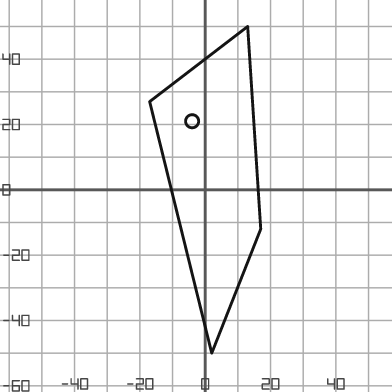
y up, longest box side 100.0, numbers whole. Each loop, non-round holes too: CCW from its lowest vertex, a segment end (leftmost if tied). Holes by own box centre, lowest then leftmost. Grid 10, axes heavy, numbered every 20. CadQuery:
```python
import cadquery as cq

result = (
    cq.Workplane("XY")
    .moveTo(2.0, -50.0)
    .lineTo(17.0, -12.0)
    .lineTo(13.0, 50.0)
    .lineTo(-17.0, 27.0)
    .close()
    .moveTo(-4.0, 21.0)
    .circle(2.0)
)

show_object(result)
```